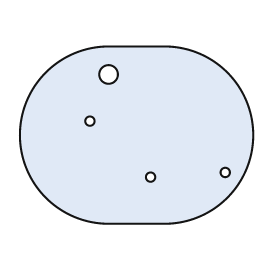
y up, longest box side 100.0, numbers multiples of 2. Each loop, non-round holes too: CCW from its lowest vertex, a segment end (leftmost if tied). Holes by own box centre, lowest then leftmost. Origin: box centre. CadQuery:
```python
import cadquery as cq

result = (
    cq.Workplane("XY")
    .moveTo(-12.0, -38.0)
    .lineTo(12.0, -38.0)
    .threePointArc((50.0, 0.0), (12.0, 38.0))
    .lineTo(-12.0, 38.0)
    .threePointArc((-50.0, 0.0), (-12.0, -38.0))
    .close()
    .moveTo(6.0, -18.0)
    .circle(2.0)
    .moveTo(38.0, -16.0)
    .circle(2.0)
    .moveTo(-20.0, 6.0)
    .circle(2.0)
    .moveTo(-12.0, 26.0)
    .circle(4.0)
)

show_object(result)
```